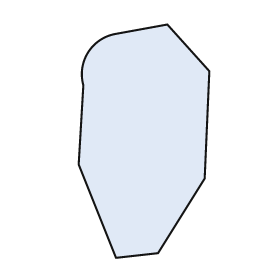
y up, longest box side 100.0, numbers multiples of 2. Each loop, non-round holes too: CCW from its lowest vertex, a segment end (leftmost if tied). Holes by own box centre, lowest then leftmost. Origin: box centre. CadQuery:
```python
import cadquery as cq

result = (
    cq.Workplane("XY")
    .moveTo(-12.0, -50.0)
    .lineTo(6.0, -48.0)
    .lineTo(26.0, -16.0)
    .lineTo(28.0, 30.0)
    .lineTo(10.0, 50.0)
    .lineTo(-12.0, 46.0)
    .threePointArc((-24.0, 38.0), (-26.0, 24.0))
    .lineTo(-28.0, -10.0)
    .close()
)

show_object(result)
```